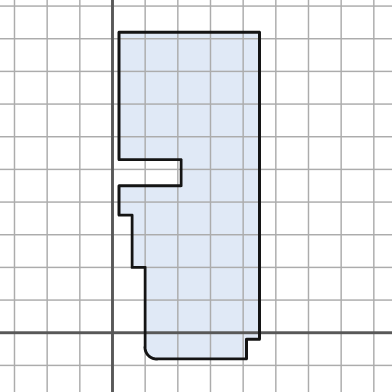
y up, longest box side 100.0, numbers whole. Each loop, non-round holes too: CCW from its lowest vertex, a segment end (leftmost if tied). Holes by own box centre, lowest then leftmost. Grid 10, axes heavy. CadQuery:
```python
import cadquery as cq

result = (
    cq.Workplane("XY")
    .moveTo(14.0, -8.0)
    .lineTo(41.0, -8.0)
    .lineTo(41.0, -2.0)
    .lineTo(45.0, -2.0)
    .lineTo(45.0, 92.0)
    .lineTo(2.0, 92.0)
    .lineTo(2.0, 53.0)
    .lineTo(21.0, 53.0)
    .lineTo(21.0, 45.0)
    .lineTo(2.0, 45.0)
    .lineTo(2.0, 36.0)
    .lineTo(6.0, 36.0)
    .lineTo(6.0, 20.0)
    .lineTo(10.0, 20.0)
    .lineTo(10.0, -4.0)
    .threePointArc((11.0, -7.0), (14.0, -8.0))
    .close()
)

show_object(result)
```